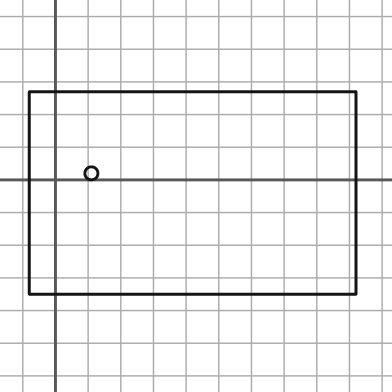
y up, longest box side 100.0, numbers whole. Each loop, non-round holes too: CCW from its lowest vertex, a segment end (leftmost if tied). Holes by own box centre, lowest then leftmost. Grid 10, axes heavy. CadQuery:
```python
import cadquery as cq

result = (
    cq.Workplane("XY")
    .moveTo(-8.0, -35.0)
    .lineTo(92.0, -35.0)
    .lineTo(92.0, 27.0)
    .lineTo(-8.0, 27.0)
    .close()
    .moveTo(11.0, 2.0)
    .circle(2.0)
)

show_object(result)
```